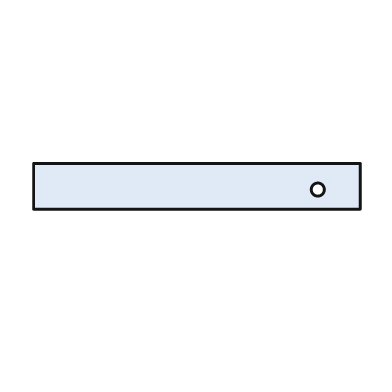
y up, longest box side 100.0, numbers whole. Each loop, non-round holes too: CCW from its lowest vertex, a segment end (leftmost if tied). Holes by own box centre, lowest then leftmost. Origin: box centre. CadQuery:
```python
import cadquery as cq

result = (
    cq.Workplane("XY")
    .moveTo(-50.0, -7.0)
    .lineTo(50.0, -7.0)
    .lineTo(50.0, 7.0)
    .lineTo(-50.0, 7.0)
    .close()
    .moveTo(37.0, -1.0)
    .circle(2.0)
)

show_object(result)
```